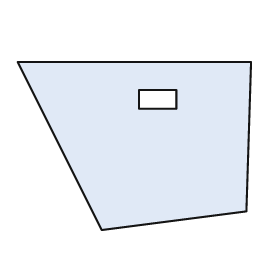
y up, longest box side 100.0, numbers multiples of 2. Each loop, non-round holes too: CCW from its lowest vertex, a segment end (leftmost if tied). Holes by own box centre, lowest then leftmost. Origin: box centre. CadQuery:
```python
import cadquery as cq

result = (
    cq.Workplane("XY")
    .moveTo(-14.0, -36.0)
    .lineTo(48.0, -28.0)
    .lineTo(50.0, 36.0)
    .lineTo(-50.0, 36.0)
    .close()
    .moveTo(2.0, 16.0)
    .lineTo(18.0, 16.0)
    .lineTo(18.0, 24.0)
    .lineTo(2.0, 24.0)
    .close()
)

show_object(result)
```